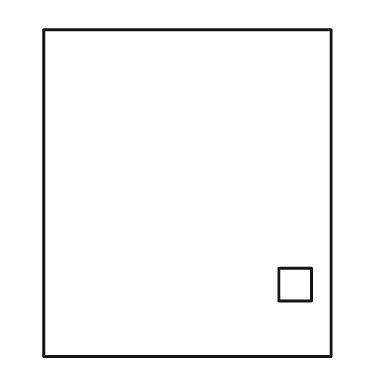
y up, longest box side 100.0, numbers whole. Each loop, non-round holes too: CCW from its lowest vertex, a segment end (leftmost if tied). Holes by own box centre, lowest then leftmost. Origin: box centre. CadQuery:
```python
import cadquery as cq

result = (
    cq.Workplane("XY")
    .moveTo(-44.0, -50.0)
    .lineTo(44.0, -50.0)
    .lineTo(44.0, 50.0)
    .lineTo(-44.0, 50.0)
    .close()
    .moveTo(28.0, -33.0)
    .lineTo(38.0, -33.0)
    .lineTo(38.0, -23.0)
    .lineTo(28.0, -23.0)
    .close()
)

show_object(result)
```